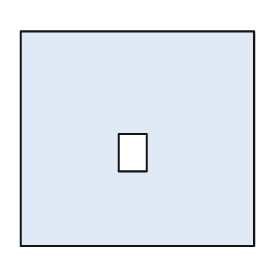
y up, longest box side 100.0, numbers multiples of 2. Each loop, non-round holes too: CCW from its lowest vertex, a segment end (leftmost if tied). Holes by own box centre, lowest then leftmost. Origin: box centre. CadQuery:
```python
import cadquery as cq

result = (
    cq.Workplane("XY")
    .moveTo(-50.0, -46.0)
    .lineTo(50.0, -46.0)
    .lineTo(50.0, 46.0)
    .lineTo(-50.0, 46.0)
    .close()
    .moveTo(-8.0, -14.0)
    .lineTo(4.0, -14.0)
    .lineTo(4.0, 2.0)
    .lineTo(-8.0, 2.0)
    .close()
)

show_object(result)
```